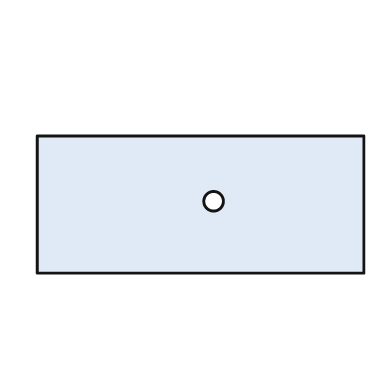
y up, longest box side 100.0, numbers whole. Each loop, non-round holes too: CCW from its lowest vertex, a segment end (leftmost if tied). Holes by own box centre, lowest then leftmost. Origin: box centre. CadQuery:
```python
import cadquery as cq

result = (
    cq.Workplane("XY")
    .moveTo(-50.0, -21.0)
    .lineTo(50.0, -21.0)
    .lineTo(50.0, 21.0)
    .lineTo(-50.0, 21.0)
    .close()
    .moveTo(4.0, 1.0)
    .circle(3.0)
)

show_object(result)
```